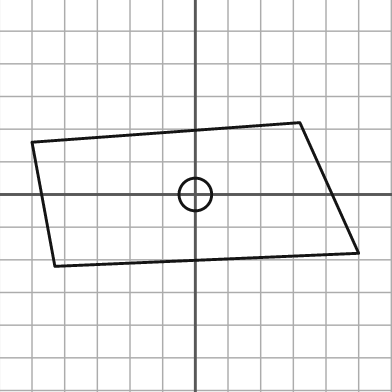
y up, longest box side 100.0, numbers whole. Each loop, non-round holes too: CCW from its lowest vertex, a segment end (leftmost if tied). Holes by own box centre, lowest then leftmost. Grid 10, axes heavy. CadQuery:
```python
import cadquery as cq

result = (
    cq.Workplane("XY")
    .moveTo(-43.0, -22.0)
    .lineTo(50.0, -18.0)
    .lineTo(32.0, 22.0)
    .lineTo(-50.0, 16.0)
    .close()
    .moveTo(0.0, 0.0)
    .circle(5.0)
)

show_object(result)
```